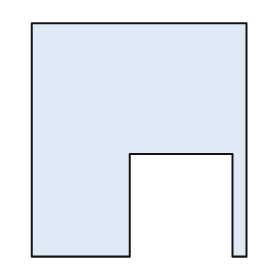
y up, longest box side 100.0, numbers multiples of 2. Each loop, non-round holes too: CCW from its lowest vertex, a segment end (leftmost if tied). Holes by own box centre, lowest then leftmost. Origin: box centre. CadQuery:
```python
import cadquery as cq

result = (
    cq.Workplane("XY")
    .moveTo(-46.0, -50.0)
    .lineTo(-4.0, -50.0)
    .lineTo(-4.0, -6.0)
    .lineTo(40.0, -6.0)
    .lineTo(40.0, -50.0)
    .lineTo(46.0, -50.0)
    .lineTo(46.0, 50.0)
    .lineTo(-46.0, 50.0)
    .close()
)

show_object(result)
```